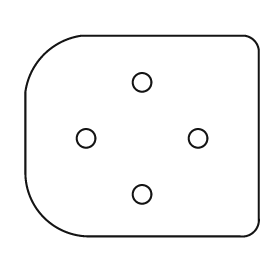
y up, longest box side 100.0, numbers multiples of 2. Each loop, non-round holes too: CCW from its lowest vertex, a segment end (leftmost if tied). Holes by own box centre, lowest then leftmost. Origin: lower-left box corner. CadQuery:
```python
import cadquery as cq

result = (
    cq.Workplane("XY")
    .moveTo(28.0, 0.0)
    .lineTo(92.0, 0.0)
    .threePointArc((98.0, 2.0), (100.0, 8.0))
    .lineTo(100.0, 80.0)
    .threePointArc((98.0, 84.0), (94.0, 86.0))
    .lineTo(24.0, 86.0)
    .threePointArc((8.0, 78.0), (0.0, 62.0))
    .lineTo(0.0, 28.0)
    .threePointArc((8.0, 8.0), (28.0, 0.0))
    .close()
    .moveTo(50.0, 18.0)
    .circle(4.0)
    .moveTo(26.0, 42.0)
    .circle(4.0)
    .moveTo(74.0, 42.0)
    .circle(4.0)
    .moveTo(50.0, 66.0)
    .circle(4.0)
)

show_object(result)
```